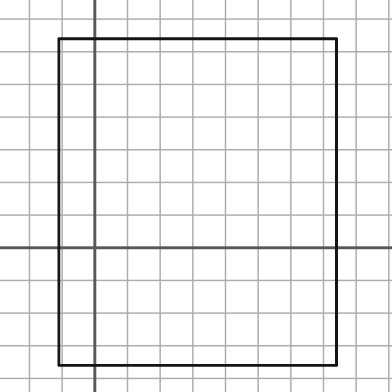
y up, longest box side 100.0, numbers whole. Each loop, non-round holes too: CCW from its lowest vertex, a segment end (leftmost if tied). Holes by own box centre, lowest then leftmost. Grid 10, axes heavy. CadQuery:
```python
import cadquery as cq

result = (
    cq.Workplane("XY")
    .moveTo(-11.0, -36.0)
    .lineTo(74.0, -36.0)
    .lineTo(74.0, 64.0)
    .lineTo(-11.0, 64.0)
    .close()
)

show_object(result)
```